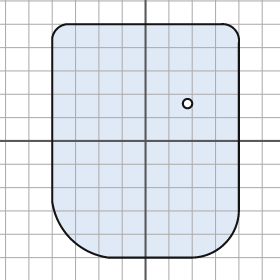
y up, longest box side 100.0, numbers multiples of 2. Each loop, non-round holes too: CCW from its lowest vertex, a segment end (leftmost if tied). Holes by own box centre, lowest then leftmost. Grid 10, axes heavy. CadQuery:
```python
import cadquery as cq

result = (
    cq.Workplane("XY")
    .moveTo(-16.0, -50.0)
    .lineTo(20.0, -50.0)
    .threePointArc((34.0, -44.0), (40.0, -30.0))
    .lineTo(40.0, 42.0)
    .threePointArc((38.0, 48.0), (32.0, 50.0))
    .lineTo(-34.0, 50.0)
    .threePointArc((-38.0, 48.0), (-40.0, 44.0))
    .lineTo(-40.0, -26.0)
    .threePointArc((-32.0, -42.0), (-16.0, -50.0))
    .close()
    .moveTo(18.0, 16.0)
    .circle(2.0)
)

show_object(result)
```